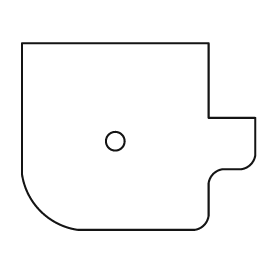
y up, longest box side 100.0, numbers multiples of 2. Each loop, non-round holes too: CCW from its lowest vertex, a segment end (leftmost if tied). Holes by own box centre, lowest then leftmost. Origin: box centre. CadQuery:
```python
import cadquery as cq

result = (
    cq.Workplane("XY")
    .moveTo(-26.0, -40.0)
    .lineTo(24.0, -40.0)
    .threePointArc((28.0, -38.0), (30.0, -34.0))
    .lineTo(30.0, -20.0)
    .threePointArc((32.0, -16.0), (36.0, -14.0))
    .lineTo(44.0, -14.0)
    .threePointArc((48.0, -12.0), (50.0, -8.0))
    .lineTo(50.0, 8.0)
    .lineTo(30.0, 8.0)
    .lineTo(30.0, 40.0)
    .lineTo(-50.0, 40.0)
    .lineTo(-50.0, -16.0)
    .threePointArc((-42.0, -32.0), (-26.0, -40.0))
    .close()
    .moveTo(-10.0, -2.0)
    .circle(4.0)
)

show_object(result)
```